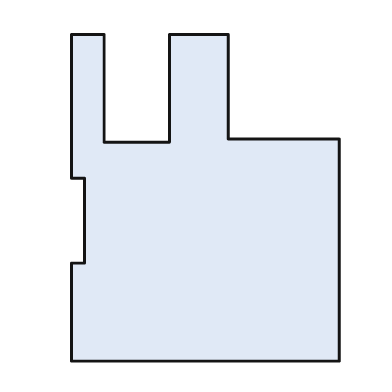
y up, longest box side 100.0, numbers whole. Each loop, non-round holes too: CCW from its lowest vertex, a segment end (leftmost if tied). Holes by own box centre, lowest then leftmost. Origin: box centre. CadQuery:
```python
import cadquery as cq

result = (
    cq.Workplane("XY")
    .moveTo(-41.0, -50.0)
    .lineTo(41.0, -50.0)
    .lineTo(41.0, 18.0)
    .lineTo(7.0, 18.0)
    .lineTo(7.0, 50.0)
    .lineTo(-11.0, 50.0)
    .lineTo(-11.0, 17.0)
    .lineTo(-31.0, 17.0)
    .lineTo(-31.0, 50.0)
    .lineTo(-41.0, 50.0)
    .lineTo(-41.0, 6.0)
    .lineTo(-37.0, 6.0)
    .lineTo(-37.0, -20.0)
    .lineTo(-41.0, -20.0)
    .close()
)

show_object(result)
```